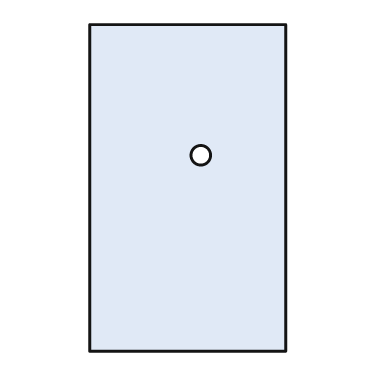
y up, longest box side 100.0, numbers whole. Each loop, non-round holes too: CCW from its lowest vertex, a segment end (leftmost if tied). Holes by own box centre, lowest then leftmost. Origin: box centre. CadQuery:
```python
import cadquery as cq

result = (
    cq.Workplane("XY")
    .moveTo(-30.0, -50.0)
    .lineTo(30.0, -50.0)
    .lineTo(30.0, 50.0)
    .lineTo(-30.0, 50.0)
    .close()
    .moveTo(4.0, 10.0)
    .circle(3.0)
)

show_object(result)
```